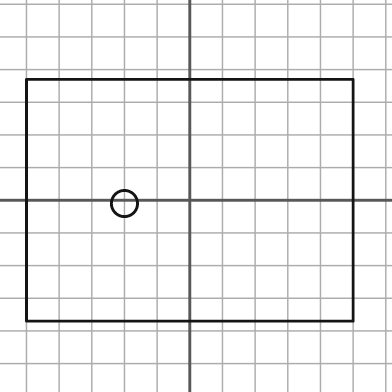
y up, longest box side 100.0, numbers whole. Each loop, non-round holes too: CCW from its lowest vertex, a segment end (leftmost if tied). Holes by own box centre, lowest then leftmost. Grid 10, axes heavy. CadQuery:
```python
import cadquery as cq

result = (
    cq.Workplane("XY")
    .moveTo(-50.0, -37.0)
    .lineTo(50.0, -37.0)
    .lineTo(50.0, 37.0)
    .lineTo(-50.0, 37.0)
    .close()
    .moveTo(-20.0, -1.0)
    .circle(4.0)
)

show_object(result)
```